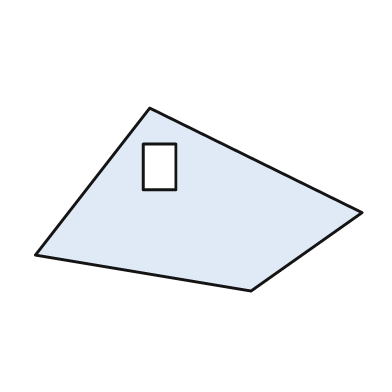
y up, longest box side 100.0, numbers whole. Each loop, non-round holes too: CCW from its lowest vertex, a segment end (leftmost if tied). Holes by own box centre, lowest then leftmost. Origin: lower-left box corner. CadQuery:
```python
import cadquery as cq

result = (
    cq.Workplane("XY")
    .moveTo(66.0, 0.0)
    .lineTo(100.0, 24.0)
    .lineTo(35.0, 56.0)
    .lineTo(0.0, 11.0)
    .close()
    .moveTo(33.0, 31.0)
    .lineTo(43.0, 31.0)
    .lineTo(43.0, 45.0)
    .lineTo(33.0, 45.0)
    .close()
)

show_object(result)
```